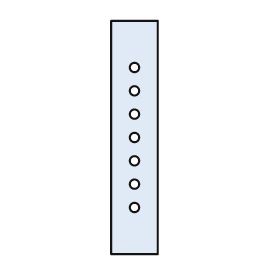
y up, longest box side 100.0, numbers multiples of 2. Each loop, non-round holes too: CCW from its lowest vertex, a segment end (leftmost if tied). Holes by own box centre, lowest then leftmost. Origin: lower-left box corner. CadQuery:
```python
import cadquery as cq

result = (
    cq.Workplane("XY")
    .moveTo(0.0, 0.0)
    .lineTo(20.0, 0.0)
    .lineTo(20.0, 100.0)
    .lineTo(0.0, 100.0)
    .close()
    .moveTo(10.0, 20.0)
    .circle(2.0)
    .moveTo(10.0, 30.0)
    .circle(2.0)
    .moveTo(10.0, 40.0)
    .circle(2.0)
    .moveTo(10.0, 50.0)
    .circle(2.0)
    .moveTo(10.0, 60.0)
    .circle(2.0)
    .moveTo(10.0, 70.0)
    .circle(2.0)
    .moveTo(10.0, 80.0)
    .circle(2.0)
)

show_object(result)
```